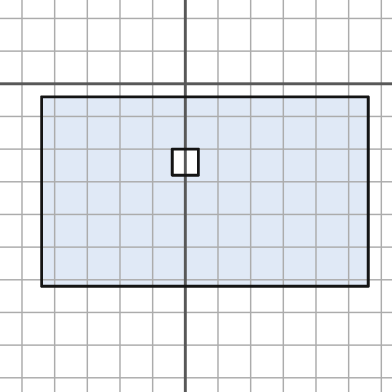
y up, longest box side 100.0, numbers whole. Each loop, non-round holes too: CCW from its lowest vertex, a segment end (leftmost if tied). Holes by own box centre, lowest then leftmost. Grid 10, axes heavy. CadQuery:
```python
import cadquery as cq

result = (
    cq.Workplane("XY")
    .moveTo(-44.0, -62.0)
    .lineTo(56.0, -62.0)
    .lineTo(56.0, -4.0)
    .lineTo(-44.0, -4.0)
    .close()
    .moveTo(-4.0, -28.0)
    .lineTo(4.0, -28.0)
    .lineTo(4.0, -20.0)
    .lineTo(-4.0, -20.0)
    .close()
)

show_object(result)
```